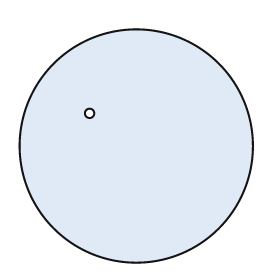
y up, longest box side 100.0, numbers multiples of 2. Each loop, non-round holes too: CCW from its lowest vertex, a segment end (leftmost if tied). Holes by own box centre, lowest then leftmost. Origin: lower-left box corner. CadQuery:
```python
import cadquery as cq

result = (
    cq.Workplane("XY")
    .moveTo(50.0, 50.0)
    .circle(50.0)
    .moveTo(30.0, 64.0)
    .circle(2.0)
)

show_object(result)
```